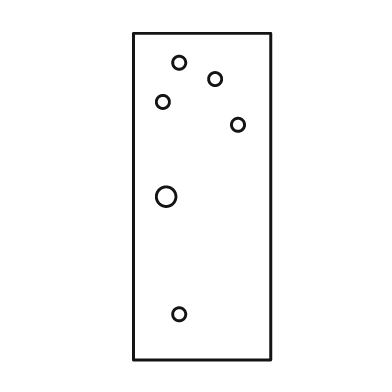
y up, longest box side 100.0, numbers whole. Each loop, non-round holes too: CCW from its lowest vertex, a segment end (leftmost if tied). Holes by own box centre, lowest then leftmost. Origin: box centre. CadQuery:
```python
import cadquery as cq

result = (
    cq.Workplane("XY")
    .moveTo(-21.0, -50.0)
    .lineTo(21.0, -50.0)
    .lineTo(21.0, 50.0)
    .lineTo(-21.0, 50.0)
    .close()
    .moveTo(-7.0, -36.0)
    .circle(2.0)
    .moveTo(-11.0, 0.0)
    .circle(3.0)
    .moveTo(11.0, 22.0)
    .circle(2.0)
    .moveTo(-12.0, 29.0)
    .circle(2.0)
    .moveTo(4.0, 36.0)
    .circle(2.0)
    .moveTo(-7.0, 41.0)
    .circle(2.0)
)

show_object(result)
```